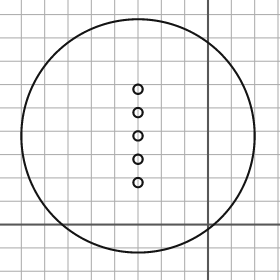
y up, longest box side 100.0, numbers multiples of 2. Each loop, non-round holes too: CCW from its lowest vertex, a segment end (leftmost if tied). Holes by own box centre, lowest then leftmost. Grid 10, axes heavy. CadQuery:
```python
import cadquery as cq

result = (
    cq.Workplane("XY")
    .moveTo(-30.0, 38.0)
    .circle(50.0)
    .moveTo(-30.0, 18.0)
    .circle(2.0)
    .moveTo(-30.0, 28.0)
    .circle(2.0)
    .moveTo(-30.0, 38.0)
    .circle(2.0)
    .moveTo(-30.0, 48.0)
    .circle(2.0)
    .moveTo(-30.0, 58.0)
    .circle(2.0)
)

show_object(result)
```